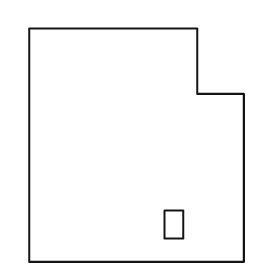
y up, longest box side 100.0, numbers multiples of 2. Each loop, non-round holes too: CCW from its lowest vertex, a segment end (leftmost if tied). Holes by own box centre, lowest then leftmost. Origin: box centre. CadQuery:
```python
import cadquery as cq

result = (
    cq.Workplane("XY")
    .moveTo(-46.0, -50.0)
    .lineTo(46.0, -50.0)
    .lineTo(46.0, 22.0)
    .lineTo(26.0, 22.0)
    .lineTo(26.0, 50.0)
    .lineTo(-46.0, 50.0)
    .close()
    .moveTo(12.0, -40.0)
    .lineTo(20.0, -40.0)
    .lineTo(20.0, -28.0)
    .lineTo(12.0, -28.0)
    .close()
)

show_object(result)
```